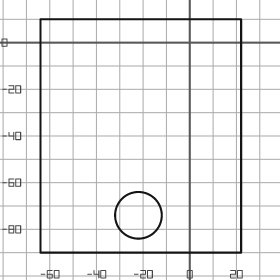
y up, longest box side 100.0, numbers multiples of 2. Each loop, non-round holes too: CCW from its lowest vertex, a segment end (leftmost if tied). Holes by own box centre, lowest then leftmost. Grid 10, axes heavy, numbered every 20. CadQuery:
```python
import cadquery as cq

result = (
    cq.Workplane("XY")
    .moveTo(-64.0, -90.0)
    .lineTo(22.0, -90.0)
    .lineTo(22.0, 10.0)
    .lineTo(-64.0, 10.0)
    .close()
    .moveTo(-22.0, -74.0)
    .circle(10.0)
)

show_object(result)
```